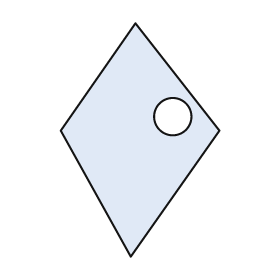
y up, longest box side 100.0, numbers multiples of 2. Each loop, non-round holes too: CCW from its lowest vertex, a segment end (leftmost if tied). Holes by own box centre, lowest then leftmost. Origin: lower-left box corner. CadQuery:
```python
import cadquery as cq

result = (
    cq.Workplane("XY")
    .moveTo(30.0, 0.0)
    .lineTo(68.0, 54.0)
    .lineTo(32.0, 100.0)
    .lineTo(0.0, 54.0)
    .close()
    .moveTo(48.0, 60.0)
    .circle(8.0)
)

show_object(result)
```